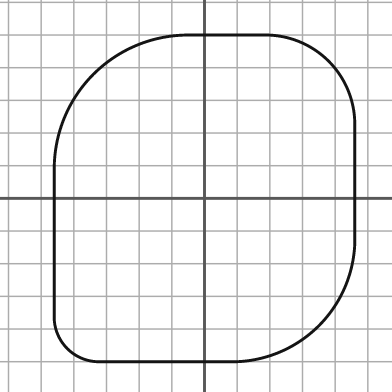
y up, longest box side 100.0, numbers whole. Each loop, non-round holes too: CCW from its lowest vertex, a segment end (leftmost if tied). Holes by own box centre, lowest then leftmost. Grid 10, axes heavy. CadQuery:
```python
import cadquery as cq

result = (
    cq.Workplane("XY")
    .moveTo(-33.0, -50.0)
    .lineTo(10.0, -50.0)
    .threePointArc((35.0, -39.0), (46.0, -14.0))
    .lineTo(46.0, 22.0)
    .threePointArc((38.0, 42.0), (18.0, 50.0))
    .lineTo(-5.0, 50.0)
    .threePointArc((-34.0, 38.0), (-46.0, 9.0))
    .lineTo(-46.0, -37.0)
    .threePointArc((-42.0, -46.0), (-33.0, -50.0))
    .close()
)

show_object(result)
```